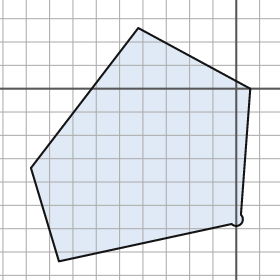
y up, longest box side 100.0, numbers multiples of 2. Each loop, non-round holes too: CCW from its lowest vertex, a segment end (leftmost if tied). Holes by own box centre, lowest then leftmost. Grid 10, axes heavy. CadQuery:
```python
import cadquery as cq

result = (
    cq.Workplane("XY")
    .moveTo(-76.0, -74.0)
    .lineTo(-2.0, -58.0)
    .threePointArc((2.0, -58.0), (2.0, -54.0))
    .lineTo(6.0, 0.0)
    .lineTo(-42.0, 26.0)
    .lineTo(-88.0, -34.0)
    .close()
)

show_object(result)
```